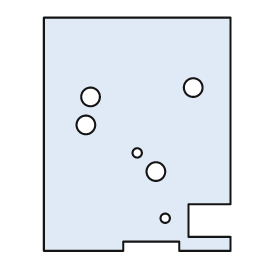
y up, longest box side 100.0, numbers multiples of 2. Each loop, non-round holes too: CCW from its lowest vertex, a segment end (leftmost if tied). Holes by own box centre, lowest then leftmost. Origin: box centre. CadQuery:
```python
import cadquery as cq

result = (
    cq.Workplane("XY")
    .moveTo(-40.0, -50.0)
    .lineTo(-6.0, -50.0)
    .lineTo(-6.0, -46.0)
    .lineTo(18.0, -46.0)
    .lineTo(18.0, -50.0)
    .lineTo(40.0, -50.0)
    .lineTo(40.0, -44.0)
    .lineTo(22.0, -44.0)
    .lineTo(22.0, -30.0)
    .lineTo(40.0, -30.0)
    .lineTo(40.0, 50.0)
    .lineTo(-40.0, 50.0)
    .close()
    .moveTo(12.0, -36.0)
    .circle(2.0)
    .moveTo(8.0, -16.0)
    .circle(4.0)
    .moveTo(0.0, -8.0)
    .circle(2.0)
    .moveTo(-22.0, 4.0)
    .circle(4.0)
    .moveTo(-20.0, 16.0)
    .circle(4.0)
    .moveTo(24.0, 20.0)
    .circle(4.0)
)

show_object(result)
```